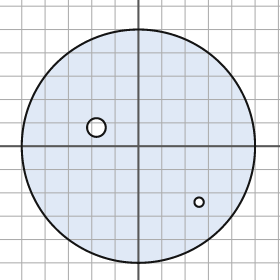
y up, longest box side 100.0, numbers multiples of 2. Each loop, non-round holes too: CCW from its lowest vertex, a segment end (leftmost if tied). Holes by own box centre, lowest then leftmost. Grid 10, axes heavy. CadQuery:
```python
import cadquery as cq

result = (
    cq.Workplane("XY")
    .moveTo(0.0, 0.0)
    .circle(50.0)
    .moveTo(26.0, -24.0)
    .circle(2.0)
    .moveTo(-18.0, 8.0)
    .circle(4.0)
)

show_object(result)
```